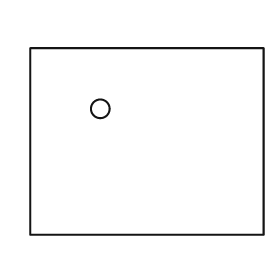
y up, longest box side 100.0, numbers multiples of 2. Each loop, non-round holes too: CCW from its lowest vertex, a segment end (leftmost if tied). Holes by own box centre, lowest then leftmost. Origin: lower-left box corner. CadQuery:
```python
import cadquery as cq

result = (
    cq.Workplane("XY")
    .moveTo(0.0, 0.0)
    .lineTo(100.0, 0.0)
    .lineTo(100.0, 80.0)
    .lineTo(0.0, 80.0)
    .close()
    .moveTo(30.0, 54.0)
    .circle(4.0)
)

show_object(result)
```